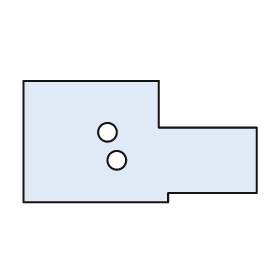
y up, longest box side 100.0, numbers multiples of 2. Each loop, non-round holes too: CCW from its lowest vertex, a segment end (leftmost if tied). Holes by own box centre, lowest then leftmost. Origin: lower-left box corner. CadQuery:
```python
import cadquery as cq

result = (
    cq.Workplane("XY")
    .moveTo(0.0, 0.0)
    .lineTo(62.0, 0.0)
    .lineTo(62.0, 4.0)
    .lineTo(100.0, 4.0)
    .lineTo(100.0, 32.0)
    .lineTo(58.0, 32.0)
    .lineTo(58.0, 52.0)
    .lineTo(0.0, 52.0)
    .close()
    .moveTo(40.0, 18.0)
    .circle(4.0)
    .moveTo(36.0, 30.0)
    .circle(4.0)
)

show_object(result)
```